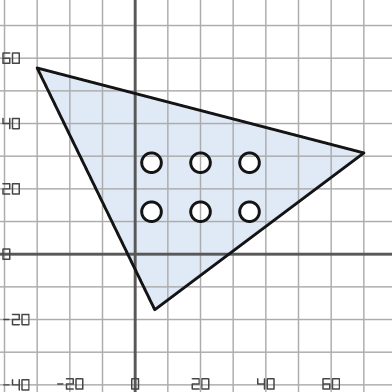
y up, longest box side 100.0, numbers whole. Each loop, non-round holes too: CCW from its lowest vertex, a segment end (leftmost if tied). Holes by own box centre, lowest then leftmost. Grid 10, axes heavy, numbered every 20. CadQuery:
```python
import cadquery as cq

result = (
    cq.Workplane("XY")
    .moveTo(6.0, -17.0)
    .lineTo(70.0, 31.0)
    .lineTo(-30.0, 57.0)
    .close()
    .moveTo(5.0, 13.0)
    .circle(3.0)
    .moveTo(20.0, 13.0)
    .circle(3.0)
    .moveTo(35.0, 13.0)
    .circle(3.0)
    .moveTo(5.0, 28.0)
    .circle(3.0)
    .moveTo(20.0, 28.0)
    .circle(3.0)
    .moveTo(35.0, 28.0)
    .circle(3.0)
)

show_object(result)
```